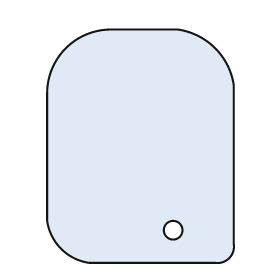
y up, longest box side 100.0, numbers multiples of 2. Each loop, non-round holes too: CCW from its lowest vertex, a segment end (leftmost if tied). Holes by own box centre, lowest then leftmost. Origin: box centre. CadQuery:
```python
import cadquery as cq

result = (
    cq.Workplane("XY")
    .moveTo(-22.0, -50.0)
    .lineTo(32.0, -50.0)
    .threePointArc((38.0, -48.0), (40.0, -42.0))
    .lineTo(40.0, 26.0)
    .threePointArc((32.0, 42.0), (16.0, 50.0))
    .lineTo(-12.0, 50.0)
    .threePointArc((-32.0, 42.0), (-40.0, 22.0))
    .lineTo(-40.0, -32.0)
    .threePointArc((-34.0, -44.0), (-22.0, -50.0))
    .close()
    .moveTo(14.0, -36.0)
    .circle(4.0)
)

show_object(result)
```